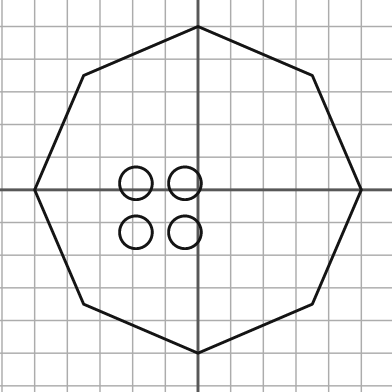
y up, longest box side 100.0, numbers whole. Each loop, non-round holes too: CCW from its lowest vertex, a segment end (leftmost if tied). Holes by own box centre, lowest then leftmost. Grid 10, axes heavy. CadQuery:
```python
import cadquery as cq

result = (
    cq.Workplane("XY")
    .moveTo(0.0, -50.0)
    .lineTo(35.0, -35.0)
    .lineTo(50.0, 0.0)
    .lineTo(35.0, 35.0)
    .lineTo(0.0, 50.0)
    .lineTo(-35.0, 35.0)
    .lineTo(-50.0, 0.0)
    .lineTo(-35.0, -35.0)
    .close()
    .moveTo(-19.0, -13.0)
    .circle(5.0)
    .moveTo(-4.0, -13.0)
    .circle(5.0)
    .moveTo(-19.0, 2.0)
    .circle(5.0)
    .moveTo(-4.0, 2.0)
    .circle(5.0)
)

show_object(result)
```